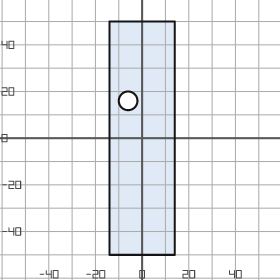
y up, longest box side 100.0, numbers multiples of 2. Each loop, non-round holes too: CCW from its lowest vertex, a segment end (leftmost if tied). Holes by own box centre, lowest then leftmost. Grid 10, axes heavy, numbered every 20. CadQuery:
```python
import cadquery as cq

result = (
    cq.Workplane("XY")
    .moveTo(-14.0, -50.0)
    .lineTo(14.0, -50.0)
    .lineTo(14.0, 50.0)
    .lineTo(-14.0, 50.0)
    .close()
    .moveTo(-6.0, 16.0)
    .circle(4.0)
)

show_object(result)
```